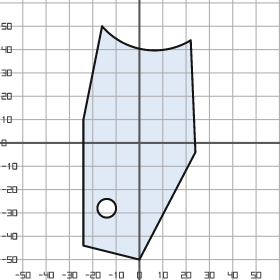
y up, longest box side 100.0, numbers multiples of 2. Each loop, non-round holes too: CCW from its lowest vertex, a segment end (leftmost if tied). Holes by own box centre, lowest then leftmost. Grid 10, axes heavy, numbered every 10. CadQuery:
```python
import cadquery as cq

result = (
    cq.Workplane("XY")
    .moveTo(0.0, -50.0)
    .lineTo(24.0, -4.0)
    .lineTo(22.0, 44.0)
    .threePointArc((2.0, 40.0), (-16.0, 50.0))
    .lineTo(-24.0, 10.0)
    .lineTo(-24.0, -44.0)
    .close()
    .moveTo(-14.0, -28.0)
    .circle(4.0)
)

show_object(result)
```